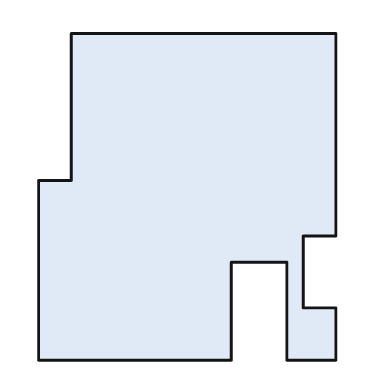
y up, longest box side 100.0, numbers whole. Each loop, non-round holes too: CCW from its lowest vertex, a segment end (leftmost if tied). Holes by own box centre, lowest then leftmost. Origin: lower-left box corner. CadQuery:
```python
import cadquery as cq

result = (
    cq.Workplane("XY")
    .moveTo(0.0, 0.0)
    .lineTo(59.0, 0.0)
    .lineTo(59.0, 30.0)
    .lineTo(76.0, 30.0)
    .lineTo(76.0, 0.0)
    .lineTo(91.0, 0.0)
    .lineTo(91.0, 16.0)
    .lineTo(81.0, 16.0)
    .lineTo(81.0, 38.0)
    .lineTo(91.0, 38.0)
    .lineTo(91.0, 100.0)
    .lineTo(10.0, 100.0)
    .lineTo(10.0, 55.0)
    .lineTo(0.0, 55.0)
    .close()
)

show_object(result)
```